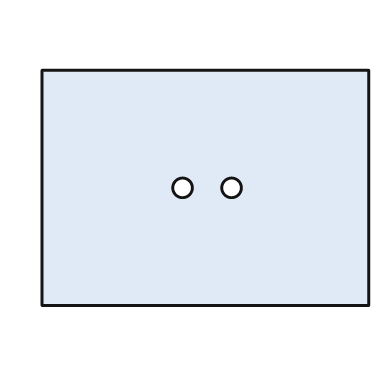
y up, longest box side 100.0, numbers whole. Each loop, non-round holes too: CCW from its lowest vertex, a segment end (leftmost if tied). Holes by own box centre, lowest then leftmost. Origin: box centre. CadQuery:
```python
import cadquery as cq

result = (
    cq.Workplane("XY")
    .moveTo(-50.0, -36.0)
    .lineTo(50.0, -36.0)
    .lineTo(50.0, 36.0)
    .lineTo(-50.0, 36.0)
    .close()
    .moveTo(-7.0, 0.0)
    .circle(3.0)
    .moveTo(8.0, 0.0)
    .circle(3.0)
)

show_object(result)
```